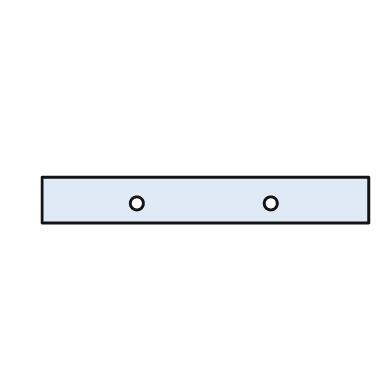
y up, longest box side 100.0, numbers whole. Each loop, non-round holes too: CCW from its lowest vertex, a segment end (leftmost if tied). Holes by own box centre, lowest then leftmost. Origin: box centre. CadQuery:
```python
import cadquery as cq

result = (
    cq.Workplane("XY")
    .moveTo(-50.0, -7.0)
    .lineTo(50.0, -7.0)
    .lineTo(50.0, 7.0)
    .lineTo(-50.0, 7.0)
    .close()
    .moveTo(-21.0, -1.0)
    .circle(2.0)
    .moveTo(20.0, -1.0)
    .circle(2.0)
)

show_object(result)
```